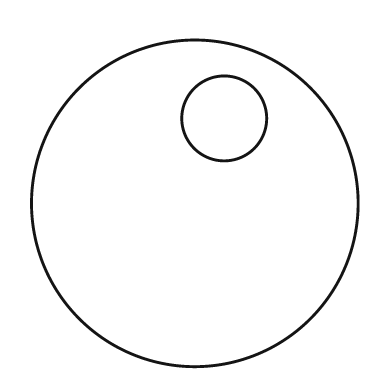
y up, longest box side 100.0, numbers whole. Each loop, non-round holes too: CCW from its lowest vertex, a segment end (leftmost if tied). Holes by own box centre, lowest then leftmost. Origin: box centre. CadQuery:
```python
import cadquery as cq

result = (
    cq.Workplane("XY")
    .moveTo(0.0, 0.0)
    .circle(50.0)
    .moveTo(9.0, 26.0)
    .circle(13.0)
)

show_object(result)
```